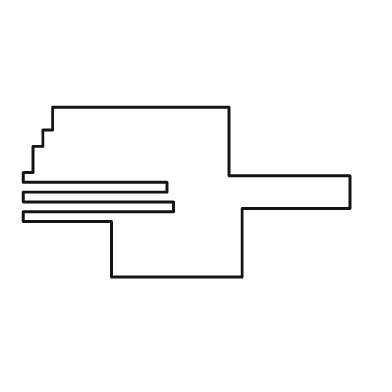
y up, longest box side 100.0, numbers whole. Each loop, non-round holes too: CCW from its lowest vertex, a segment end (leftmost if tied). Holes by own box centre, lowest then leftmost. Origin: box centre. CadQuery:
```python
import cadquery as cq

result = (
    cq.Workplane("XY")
    .moveTo(-23.0, -26.0)
    .lineTo(17.0, -26.0)
    .lineTo(17.0, -5.0)
    .lineTo(50.0, -5.0)
    .lineTo(50.0, 5.0)
    .lineTo(13.0, 5.0)
    .lineTo(13.0, 26.0)
    .lineTo(-41.0, 26.0)
    .lineTo(-41.0, 19.0)
    .lineTo(-44.0, 19.0)
    .lineTo(-44.0, 14.0)
    .lineTo(-47.0, 14.0)
    .lineTo(-47.0, 6.0)
    .lineTo(-50.0, 6.0)
    .lineTo(-50.0, 3.0)
    .lineTo(-6.0, 3.0)
    .lineTo(-6.0, 0.0)
    .lineTo(-50.0, 0.0)
    .lineTo(-50.0, -3.0)
    .lineTo(-4.0, -3.0)
    .lineTo(-4.0, -6.0)
    .lineTo(-50.0, -6.0)
    .lineTo(-50.0, -9.0)
    .lineTo(-23.0, -9.0)
    .close()
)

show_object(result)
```